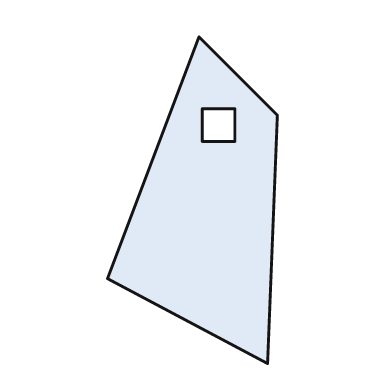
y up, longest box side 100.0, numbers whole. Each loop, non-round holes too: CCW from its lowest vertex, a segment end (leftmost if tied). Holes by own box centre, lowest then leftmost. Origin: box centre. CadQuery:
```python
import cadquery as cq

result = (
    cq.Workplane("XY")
    .moveTo(23.0, -50.0)
    .lineTo(26.0, 26.0)
    .lineTo(2.0, 50.0)
    .lineTo(-26.0, -24.0)
    .close()
    .moveTo(3.0, 18.0)
    .lineTo(13.0, 18.0)
    .lineTo(13.0, 28.0)
    .lineTo(3.0, 28.0)
    .close()
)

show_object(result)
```